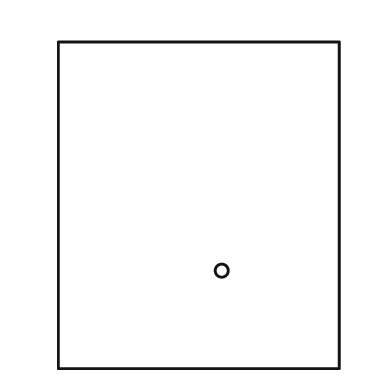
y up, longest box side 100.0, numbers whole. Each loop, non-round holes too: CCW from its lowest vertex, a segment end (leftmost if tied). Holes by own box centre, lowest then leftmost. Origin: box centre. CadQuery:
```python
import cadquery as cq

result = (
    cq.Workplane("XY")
    .moveTo(-43.0, -50.0)
    .lineTo(43.0, -50.0)
    .lineTo(43.0, 50.0)
    .lineTo(-43.0, 50.0)
    .close()
    .moveTo(7.0, -20.0)
    .circle(2.0)
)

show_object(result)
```